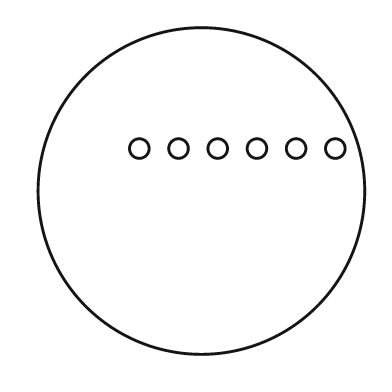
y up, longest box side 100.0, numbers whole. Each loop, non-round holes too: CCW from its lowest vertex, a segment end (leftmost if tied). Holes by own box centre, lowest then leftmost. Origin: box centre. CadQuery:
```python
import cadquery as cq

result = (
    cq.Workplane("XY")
    .moveTo(0.0, 0.0)
    .circle(50.0)
    .moveTo(-19.0, 13.0)
    .circle(3.0)
    .moveTo(-7.0, 13.0)
    .circle(3.0)
    .moveTo(5.0, 13.0)
    .circle(3.0)
    .moveTo(17.0, 13.0)
    .circle(3.0)
    .moveTo(29.0, 13.0)
    .circle(3.0)
    .moveTo(41.0, 13.0)
    .circle(3.0)
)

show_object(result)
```